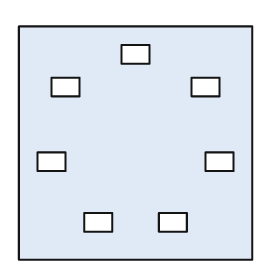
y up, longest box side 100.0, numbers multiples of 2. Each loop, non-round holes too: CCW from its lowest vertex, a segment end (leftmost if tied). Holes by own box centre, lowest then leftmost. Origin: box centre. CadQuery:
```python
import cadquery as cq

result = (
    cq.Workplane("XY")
    .moveTo(-50.0, -50.0)
    .lineTo(50.0, -50.0)
    .lineTo(50.0, 50.0)
    .lineTo(-50.0, 50.0)
    .close()
    .moveTo(-22.0, -38.0)
    .lineTo(-10.0, -38.0)
    .lineTo(-10.0, -30.0)
    .lineTo(-22.0, -30.0)
    .close()
    .moveTo(10.0, -38.0)
    .lineTo(22.0, -38.0)
    .lineTo(22.0, -30.0)
    .lineTo(10.0, -30.0)
    .close()
    .moveTo(-42.0, -12.0)
    .lineTo(-30.0, -12.0)
    .lineTo(-30.0, -4.0)
    .lineTo(-42.0, -4.0)
    .close()
    .moveTo(30.0, -12.0)
    .lineTo(42.0, -12.0)
    .lineTo(42.0, -4.0)
    .lineTo(30.0, -4.0)
    .close()
    .moveTo(-36.0, 20.0)
    .lineTo(-24.0, 20.0)
    .lineTo(-24.0, 28.0)
    .lineTo(-36.0, 28.0)
    .close()
    .moveTo(24.0, 20.0)
    .lineTo(36.0, 20.0)
    .lineTo(36.0, 28.0)
    .lineTo(24.0, 28.0)
    .close()
    .moveTo(-6.0, 34.0)
    .lineTo(6.0, 34.0)
    .lineTo(6.0, 42.0)
    .lineTo(-6.0, 42.0)
    .close()
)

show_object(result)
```